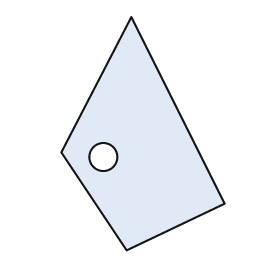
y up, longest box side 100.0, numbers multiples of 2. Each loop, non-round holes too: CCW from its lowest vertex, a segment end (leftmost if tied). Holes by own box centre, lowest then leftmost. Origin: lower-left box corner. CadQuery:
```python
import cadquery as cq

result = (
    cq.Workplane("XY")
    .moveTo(28.0, 0.0)
    .lineTo(70.0, 20.0)
    .lineTo(30.0, 100.0)
    .lineTo(0.0, 42.0)
    .close()
    .moveTo(18.0, 40.0)
    .circle(6.0)
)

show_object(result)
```